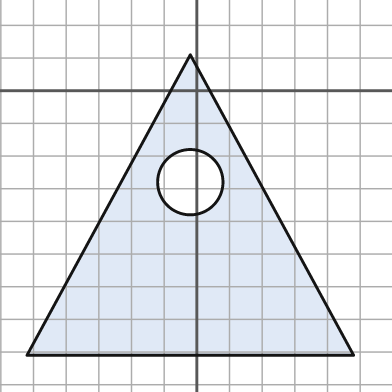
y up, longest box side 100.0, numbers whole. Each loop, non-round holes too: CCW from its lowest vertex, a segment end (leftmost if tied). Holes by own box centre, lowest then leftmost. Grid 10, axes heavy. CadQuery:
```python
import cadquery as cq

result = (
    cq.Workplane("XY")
    .moveTo(-52.0, -81.0)
    .lineTo(48.0, -81.0)
    .lineTo(-2.0, 11.0)
    .close()
    .moveTo(-2.0, -28.0)
    .circle(10.0)
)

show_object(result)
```